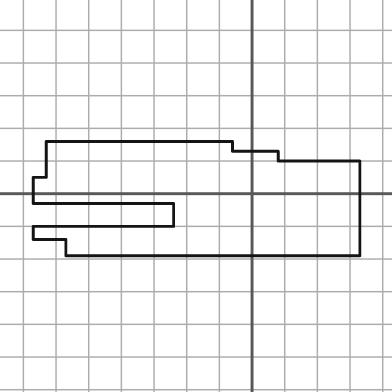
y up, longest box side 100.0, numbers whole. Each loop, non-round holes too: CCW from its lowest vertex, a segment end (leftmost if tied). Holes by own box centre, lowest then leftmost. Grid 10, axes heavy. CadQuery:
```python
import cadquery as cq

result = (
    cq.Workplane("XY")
    .moveTo(-57.0, -19.0)
    .lineTo(33.0, -19.0)
    .lineTo(33.0, 10.0)
    .lineTo(8.0, 10.0)
    .lineTo(8.0, 13.0)
    .lineTo(-6.0, 13.0)
    .lineTo(-6.0, 16.0)
    .lineTo(-63.0, 16.0)
    .lineTo(-63.0, 5.0)
    .lineTo(-67.0, 5.0)
    .lineTo(-67.0, -3.0)
    .lineTo(-24.0, -3.0)
    .lineTo(-24.0, -10.0)
    .lineTo(-67.0, -10.0)
    .lineTo(-67.0, -14.0)
    .lineTo(-57.0, -14.0)
    .close()
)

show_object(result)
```